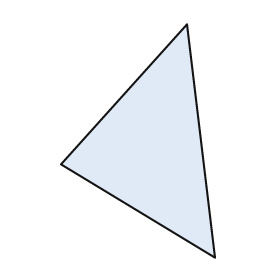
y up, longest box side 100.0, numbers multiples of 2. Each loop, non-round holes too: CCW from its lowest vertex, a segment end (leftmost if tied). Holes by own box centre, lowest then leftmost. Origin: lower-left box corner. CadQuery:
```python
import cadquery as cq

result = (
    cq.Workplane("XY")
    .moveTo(66.0, 0.0)
    .lineTo(54.0, 100.0)
    .lineTo(0.0, 40.0)
    .close()
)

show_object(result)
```